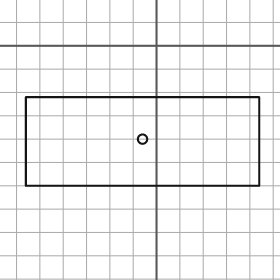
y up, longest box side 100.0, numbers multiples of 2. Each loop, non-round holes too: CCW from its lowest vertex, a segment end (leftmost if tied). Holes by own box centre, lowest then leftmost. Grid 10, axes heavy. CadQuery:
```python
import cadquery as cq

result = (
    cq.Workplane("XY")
    .moveTo(-56.0, -60.0)
    .lineTo(44.0, -60.0)
    .lineTo(44.0, -22.0)
    .lineTo(-56.0, -22.0)
    .close()
    .moveTo(-6.0, -40.0)
    .circle(2.0)
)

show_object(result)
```